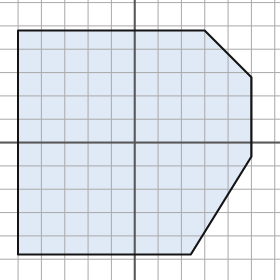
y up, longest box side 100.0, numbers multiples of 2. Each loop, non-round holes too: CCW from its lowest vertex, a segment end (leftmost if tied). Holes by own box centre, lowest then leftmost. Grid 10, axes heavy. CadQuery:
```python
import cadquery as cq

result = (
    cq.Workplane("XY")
    .moveTo(-50.0, -48.0)
    .lineTo(24.0, -48.0)
    .lineTo(50.0, -6.0)
    .lineTo(50.0, 28.0)
    .lineTo(30.0, 48.0)
    .lineTo(-50.0, 48.0)
    .close()
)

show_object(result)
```